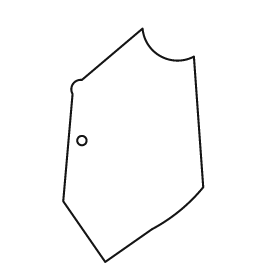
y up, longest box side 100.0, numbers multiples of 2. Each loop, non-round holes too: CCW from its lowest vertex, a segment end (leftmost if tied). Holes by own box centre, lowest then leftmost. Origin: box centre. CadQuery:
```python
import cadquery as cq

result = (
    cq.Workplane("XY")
    .moveTo(-12.0, -50.0)
    .lineTo(8.0, -36.0)
    .threePointArc((20.0, -28.0), (30.0, -18.0))
    .lineTo(26.0, 38.0)
    .threePointArc((12.0, 38.0), (4.0, 50.0))
    .lineTo(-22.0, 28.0)
    .threePointArc((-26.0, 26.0), (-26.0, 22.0))
    .lineTo(-30.0, -24.0)
    .close()
    .moveTo(-22.0, 2.0)
    .circle(2.0)
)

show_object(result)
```